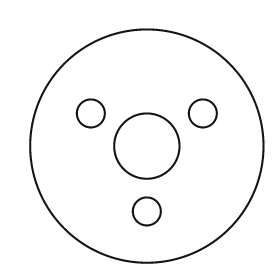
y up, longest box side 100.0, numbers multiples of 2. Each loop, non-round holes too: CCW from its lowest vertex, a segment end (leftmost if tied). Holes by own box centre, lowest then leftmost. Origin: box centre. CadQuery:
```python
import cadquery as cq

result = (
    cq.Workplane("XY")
    .moveTo(0.0, 0.0)
    .circle(50.0)
    .moveTo(0.0, -28.0)
    .circle(6.0)
    .moveTo(0.0, 0.0)
    .circle(14.0)
    .moveTo(-24.0, 14.0)
    .circle(6.0)
    .moveTo(24.0, 14.0)
    .circle(6.0)
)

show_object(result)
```